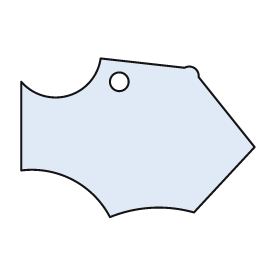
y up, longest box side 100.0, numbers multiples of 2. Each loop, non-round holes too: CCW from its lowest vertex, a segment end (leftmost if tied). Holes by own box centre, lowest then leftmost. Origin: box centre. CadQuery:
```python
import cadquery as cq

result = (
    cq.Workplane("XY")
    .moveTo(-12.0, -34.0)
    .threePointArc((6.0, -30.0), (24.0, -32.0))
    .lineTo(50.0, -4.0)
    .lineTo(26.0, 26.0)
    .threePointArc((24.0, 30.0), (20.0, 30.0))
    .lineTo(-16.0, 34.0)
    .threePointArc((-30.0, 18.0), (-50.0, 24.0))
    .lineTo(-50.0, -14.0)
    .threePointArc((-28.0, -18.0), (-12.0, -34.0))
    .close()
    .moveTo(-8.0, 24.0)
    .circle(4.0)
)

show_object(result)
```